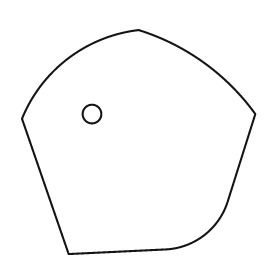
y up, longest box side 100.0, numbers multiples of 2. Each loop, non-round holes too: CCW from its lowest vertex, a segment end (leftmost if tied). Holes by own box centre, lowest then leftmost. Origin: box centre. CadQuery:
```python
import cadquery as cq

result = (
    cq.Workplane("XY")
    .moveTo(-30.0, -48.0)
    .lineTo(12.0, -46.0)
    .threePointArc((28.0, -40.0), (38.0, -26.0))
    .lineTo(50.0, 12.0)
    .threePointArc((28.0, 34.0), (0.0, 48.0))
    .threePointArc((-30.0, 36.0), (-50.0, 10.0))
    .close()
    .moveTo(-20.0, 12.0)
    .circle(4.0)
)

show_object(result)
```